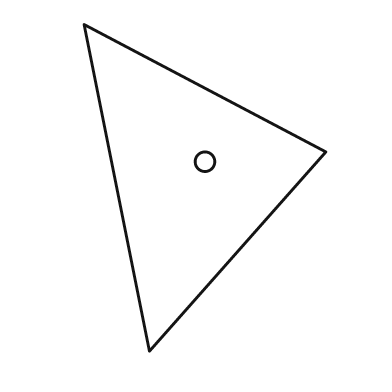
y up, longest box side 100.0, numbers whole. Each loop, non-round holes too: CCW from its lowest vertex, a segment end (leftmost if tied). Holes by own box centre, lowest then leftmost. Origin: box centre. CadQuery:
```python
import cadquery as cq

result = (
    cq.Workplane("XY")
    .moveTo(-17.0, -50.0)
    .lineTo(37.0, 11.0)
    .lineTo(-37.0, 50.0)
    .close()
    .moveTo(0.0, 8.0)
    .circle(3.0)
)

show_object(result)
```